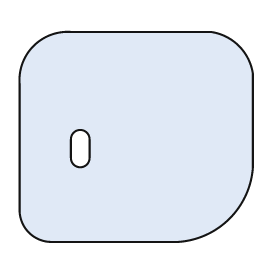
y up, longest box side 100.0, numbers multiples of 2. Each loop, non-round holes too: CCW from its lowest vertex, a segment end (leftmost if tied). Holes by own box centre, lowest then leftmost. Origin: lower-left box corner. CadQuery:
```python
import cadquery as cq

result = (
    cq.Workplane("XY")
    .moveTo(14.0, 0.0)
    .lineTo(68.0, 0.0)
    .threePointArc((90.0, 10.0), (100.0, 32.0))
    .lineTo(100.0, 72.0)
    .threePointArc((94.0, 84.0), (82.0, 90.0))
    .lineTo(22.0, 90.0)
    .threePointArc((6.0, 84.0), (0.0, 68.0))
    .lineTo(0.0, 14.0)
    .threePointArc((4.0, 4.0), (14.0, 0.0))
    .close()
    .moveTo(22.0, 36.0)
    .threePointArc((26.0, 32.0), (30.0, 36.0))
    .lineTo(30.0, 44.0)
    .threePointArc((26.0, 48.0), (22.0, 44.0))
    .close()
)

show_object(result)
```